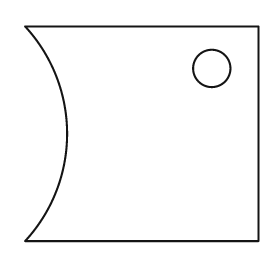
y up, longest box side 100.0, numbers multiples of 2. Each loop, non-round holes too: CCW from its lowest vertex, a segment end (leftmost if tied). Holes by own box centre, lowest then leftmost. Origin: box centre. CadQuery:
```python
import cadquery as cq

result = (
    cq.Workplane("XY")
    .moveTo(-50.0, -46.0)
    .lineTo(50.0, -46.0)
    .lineTo(50.0, 46.0)
    .lineTo(-50.0, 46.0)
    .threePointArc((-32.0, 0.0), (-50.0, -46.0))
    .close()
    .moveTo(30.0, 28.0)
    .circle(8.0)
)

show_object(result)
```